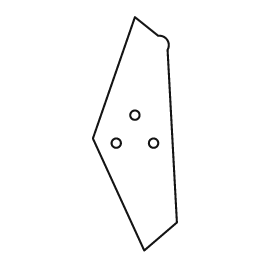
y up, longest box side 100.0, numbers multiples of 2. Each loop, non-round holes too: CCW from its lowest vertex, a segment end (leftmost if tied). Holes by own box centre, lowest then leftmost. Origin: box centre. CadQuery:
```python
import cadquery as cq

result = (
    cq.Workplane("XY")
    .moveTo(4.0, -50.0)
    .lineTo(18.0, -38.0)
    .lineTo(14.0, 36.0)
    .threePointArc((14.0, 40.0), (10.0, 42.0))
    .lineTo(0.0, 50.0)
    .lineTo(-18.0, -2.0)
    .close()
    .moveTo(-8.0, -4.0)
    .circle(2.0)
    .moveTo(8.0, -4.0)
    .circle(2.0)
    .moveTo(0.0, 8.0)
    .circle(2.0)
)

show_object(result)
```